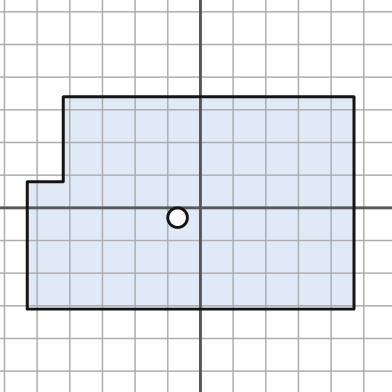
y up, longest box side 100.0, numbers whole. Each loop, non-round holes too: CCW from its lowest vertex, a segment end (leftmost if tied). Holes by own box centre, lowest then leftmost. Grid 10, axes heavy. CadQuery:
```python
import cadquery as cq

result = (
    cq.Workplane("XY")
    .moveTo(-53.0, -31.0)
    .lineTo(47.0, -31.0)
    .lineTo(47.0, 34.0)
    .lineTo(-42.0, 34.0)
    .lineTo(-42.0, 8.0)
    .lineTo(-53.0, 8.0)
    .close()
    .moveTo(-7.0, -3.0)
    .circle(3.0)
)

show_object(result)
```